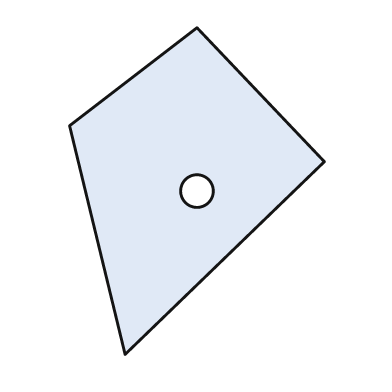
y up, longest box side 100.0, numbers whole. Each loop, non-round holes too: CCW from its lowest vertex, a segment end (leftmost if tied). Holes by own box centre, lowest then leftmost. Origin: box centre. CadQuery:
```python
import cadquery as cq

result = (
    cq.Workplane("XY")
    .moveTo(-22.0, -50.0)
    .lineTo(39.0, 9.0)
    .lineTo(0.0, 50.0)
    .lineTo(-39.0, 20.0)
    .close()
    .moveTo(0.0, 0.0)
    .circle(5.0)
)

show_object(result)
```